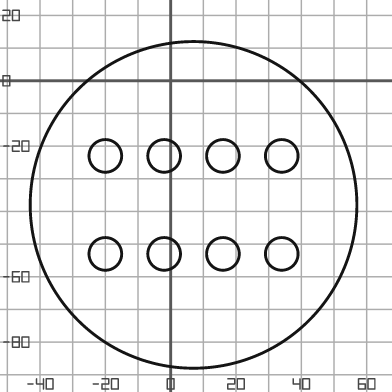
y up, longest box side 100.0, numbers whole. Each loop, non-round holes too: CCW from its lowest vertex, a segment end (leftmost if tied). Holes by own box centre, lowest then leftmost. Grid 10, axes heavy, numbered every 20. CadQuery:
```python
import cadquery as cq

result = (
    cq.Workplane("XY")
    .moveTo(7.0, -38.0)
    .circle(50.0)
    .moveTo(-20.0, -53.0)
    .circle(5.0)
    .moveTo(-2.0, -53.0)
    .circle(5.0)
    .moveTo(16.0, -53.0)
    .circle(5.0)
    .moveTo(34.0, -53.0)
    .circle(5.0)
    .moveTo(-20.0, -23.0)
    .circle(5.0)
    .moveTo(-2.0, -23.0)
    .circle(5.0)
    .moveTo(16.0, -23.0)
    .circle(5.0)
    .moveTo(34.0, -23.0)
    .circle(5.0)
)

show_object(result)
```